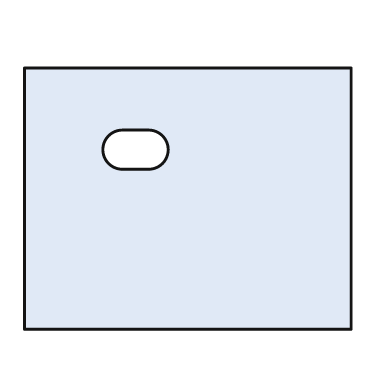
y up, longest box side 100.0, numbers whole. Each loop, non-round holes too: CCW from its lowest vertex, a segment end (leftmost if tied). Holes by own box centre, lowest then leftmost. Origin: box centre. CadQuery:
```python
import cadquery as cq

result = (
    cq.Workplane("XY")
    .moveTo(-50.0, -40.0)
    .lineTo(50.0, -40.0)
    .lineTo(50.0, 40.0)
    .lineTo(-50.0, 40.0)
    .close()
    .moveTo(-20.0, 9.0)
    .lineTo(-12.0, 9.0)
    .threePointArc((-6.0, 15.0), (-12.0, 21.0))
    .lineTo(-20.0, 21.0)
    .threePointArc((-26.0, 15.0), (-20.0, 9.0))
    .close()
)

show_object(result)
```